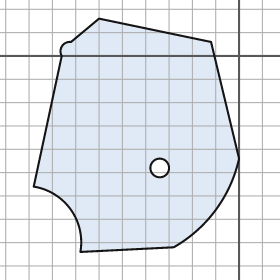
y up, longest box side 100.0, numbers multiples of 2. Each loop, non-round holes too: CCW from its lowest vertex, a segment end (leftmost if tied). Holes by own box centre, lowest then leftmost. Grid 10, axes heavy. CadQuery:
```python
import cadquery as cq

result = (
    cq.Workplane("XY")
    .moveTo(-68.0, -84.0)
    .lineTo(-28.0, -82.0)
    .threePointArc((-10.0, -66.0), (0.0, -44.0))
    .lineTo(-12.0, 6.0)
    .lineTo(-60.0, 16.0)
    .lineTo(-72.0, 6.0)
    .threePointArc((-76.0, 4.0), (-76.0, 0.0))
    .lineTo(-88.0, -56.0)
    .threePointArc((-72.0, -66.0), (-68.0, -84.0))
    .close()
    .moveTo(-34.0, -48.0)
    .circle(4.0)
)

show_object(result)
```